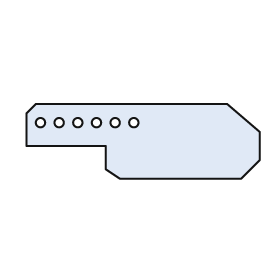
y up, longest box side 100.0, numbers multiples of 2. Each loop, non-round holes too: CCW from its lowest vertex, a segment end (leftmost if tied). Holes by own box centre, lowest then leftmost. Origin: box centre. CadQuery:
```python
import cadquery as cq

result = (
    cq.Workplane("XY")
    .moveTo(-10.0, -16.0)
    .lineTo(42.0, -16.0)
    .lineTo(50.0, -8.0)
    .lineTo(50.0, 4.0)
    .lineTo(36.0, 16.0)
    .lineTo(-46.0, 16.0)
    .lineTo(-50.0, 12.0)
    .lineTo(-50.0, -2.0)
    .lineTo(-16.0, -2.0)
    .lineTo(-16.0, -12.0)
    .close()
    .moveTo(-44.0, 8.0)
    .circle(2.0)
    .moveTo(-36.0, 8.0)
    .circle(2.0)
    .moveTo(-28.0, 8.0)
    .circle(2.0)
    .moveTo(-20.0, 8.0)
    .circle(2.0)
    .moveTo(-12.0, 8.0)
    .circle(2.0)
    .moveTo(-4.0, 8.0)
    .circle(2.0)
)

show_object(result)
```